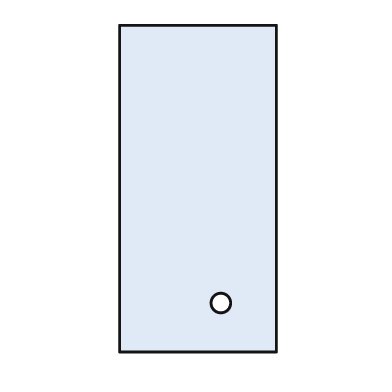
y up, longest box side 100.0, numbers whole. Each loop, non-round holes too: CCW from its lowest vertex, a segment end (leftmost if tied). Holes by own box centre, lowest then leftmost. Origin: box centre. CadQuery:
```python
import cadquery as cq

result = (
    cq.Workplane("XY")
    .moveTo(-24.0, -50.0)
    .lineTo(24.0, -50.0)
    .lineTo(24.0, 50.0)
    .lineTo(-24.0, 50.0)
    .close()
    .moveTo(7.0, -35.0)
    .circle(3.0)
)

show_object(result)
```